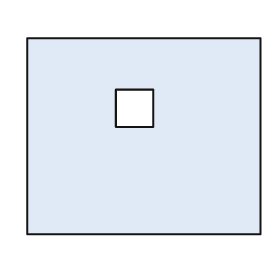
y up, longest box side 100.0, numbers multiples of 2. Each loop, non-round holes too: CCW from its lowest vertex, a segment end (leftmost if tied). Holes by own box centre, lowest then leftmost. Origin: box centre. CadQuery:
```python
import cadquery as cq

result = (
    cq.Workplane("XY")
    .moveTo(-50.0, -42.0)
    .lineTo(50.0, -42.0)
    .lineTo(50.0, 42.0)
    .lineTo(-50.0, 42.0)
    .close()
    .moveTo(-12.0, 4.0)
    .lineTo(4.0, 4.0)
    .lineTo(4.0, 20.0)
    .lineTo(-12.0, 20.0)
    .close()
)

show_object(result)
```